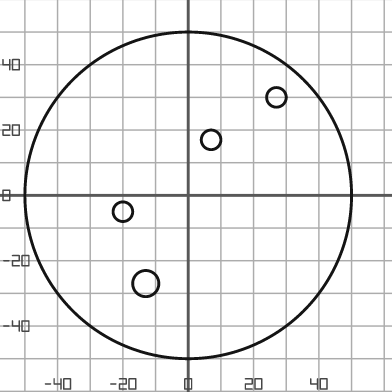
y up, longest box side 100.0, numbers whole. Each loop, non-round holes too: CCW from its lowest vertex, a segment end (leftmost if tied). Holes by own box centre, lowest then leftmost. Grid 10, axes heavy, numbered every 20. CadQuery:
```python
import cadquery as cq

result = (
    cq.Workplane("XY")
    .moveTo(0.0, 0.0)
    .circle(50.0)
    .moveTo(-13.0, -27.0)
    .circle(4.0)
    .moveTo(-20.0, -5.0)
    .circle(3.0)
    .moveTo(7.0, 17.0)
    .circle(3.0)
    .moveTo(27.0, 30.0)
    .circle(3.0)
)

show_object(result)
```